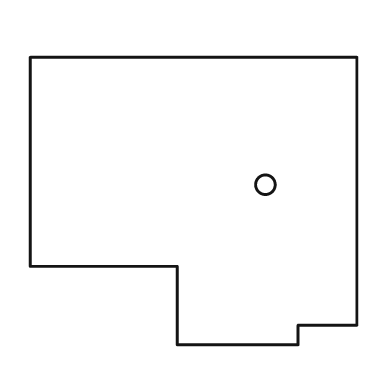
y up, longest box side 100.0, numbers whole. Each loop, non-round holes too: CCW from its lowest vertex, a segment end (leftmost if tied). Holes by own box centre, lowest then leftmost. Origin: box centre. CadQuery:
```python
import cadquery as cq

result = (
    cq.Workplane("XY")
    .moveTo(-5.0, -44.0)
    .lineTo(32.0, -44.0)
    .lineTo(32.0, -38.0)
    .lineTo(50.0, -38.0)
    .lineTo(50.0, 44.0)
    .lineTo(-50.0, 44.0)
    .lineTo(-50.0, -20.0)
    .lineTo(-5.0, -20.0)
    .close()
    .moveTo(22.0, 5.0)
    .circle(3.0)
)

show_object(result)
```